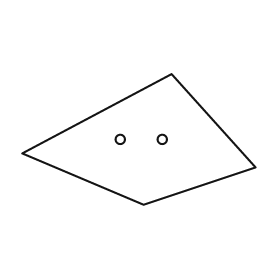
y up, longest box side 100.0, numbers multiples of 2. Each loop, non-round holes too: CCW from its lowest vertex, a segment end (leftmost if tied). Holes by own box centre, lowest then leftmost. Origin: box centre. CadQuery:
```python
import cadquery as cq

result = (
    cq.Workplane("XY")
    .moveTo(2.0, -28.0)
    .lineTo(50.0, -12.0)
    .lineTo(14.0, 28.0)
    .lineTo(-50.0, -6.0)
    .close()
    .moveTo(-8.0, 0.0)
    .circle(2.0)
    .moveTo(10.0, 0.0)
    .circle(2.0)
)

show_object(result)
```